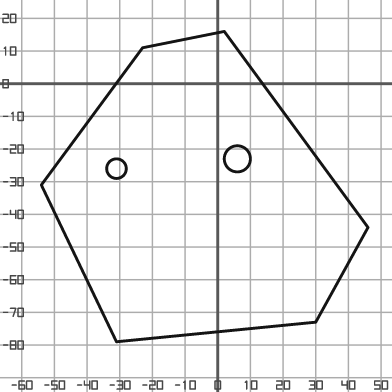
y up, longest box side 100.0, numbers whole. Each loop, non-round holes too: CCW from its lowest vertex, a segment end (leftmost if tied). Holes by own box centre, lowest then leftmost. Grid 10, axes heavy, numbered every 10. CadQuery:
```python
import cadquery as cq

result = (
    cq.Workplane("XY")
    .moveTo(-31.0, -79.0)
    .lineTo(30.0, -73.0)
    .lineTo(46.0, -44.0)
    .lineTo(2.0, 16.0)
    .lineTo(-23.0, 11.0)
    .lineTo(-54.0, -31.0)
    .close()
    .moveTo(-31.0, -26.0)
    .circle(3.0)
    .moveTo(6.0, -23.0)
    .circle(4.0)
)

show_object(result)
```